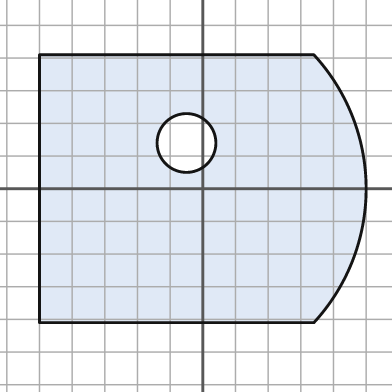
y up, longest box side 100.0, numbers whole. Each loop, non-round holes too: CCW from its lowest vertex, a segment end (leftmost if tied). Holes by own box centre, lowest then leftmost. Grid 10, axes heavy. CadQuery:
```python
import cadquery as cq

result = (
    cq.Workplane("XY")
    .moveTo(-50.0, -41.0)
    .lineTo(34.0, -41.0)
    .threePointArc((50.0, 0.0), (34.0, 41.0))
    .lineTo(-50.0, 41.0)
    .close()
    .moveTo(-5.0, 14.0)
    .circle(9.0)
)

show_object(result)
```